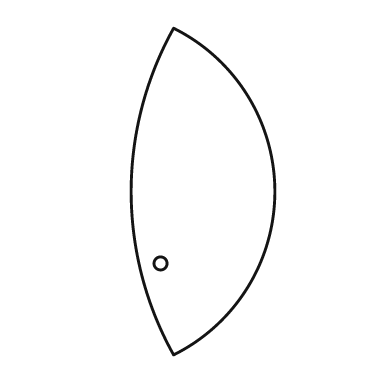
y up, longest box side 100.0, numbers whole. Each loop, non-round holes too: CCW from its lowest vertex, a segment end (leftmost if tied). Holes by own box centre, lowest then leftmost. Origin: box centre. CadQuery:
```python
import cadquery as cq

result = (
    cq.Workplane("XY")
    .moveTo(-9.0, -50.0)
    .threePointArc((22.0, 0.0), (-9.0, 50.0))
    .threePointArc((-22.0, 0.0), (-9.0, -50.0))
    .close()
    .moveTo(-13.0, -22.0)
    .circle(2.0)
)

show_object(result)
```